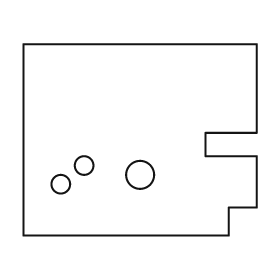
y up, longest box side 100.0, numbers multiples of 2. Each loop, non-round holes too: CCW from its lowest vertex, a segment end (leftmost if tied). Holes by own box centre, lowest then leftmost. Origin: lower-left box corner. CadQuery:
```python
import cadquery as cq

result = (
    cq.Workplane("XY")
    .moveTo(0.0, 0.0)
    .lineTo(88.0, 0.0)
    .lineTo(88.0, 12.0)
    .lineTo(100.0, 12.0)
    .lineTo(100.0, 34.0)
    .lineTo(78.0, 34.0)
    .lineTo(78.0, 44.0)
    .lineTo(100.0, 44.0)
    .lineTo(100.0, 82.0)
    .lineTo(0.0, 82.0)
    .close()
    .moveTo(16.0, 22.0)
    .circle(4.0)
    .moveTo(50.0, 26.0)
    .circle(6.0)
    .moveTo(26.0, 30.0)
    .circle(4.0)
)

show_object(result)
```